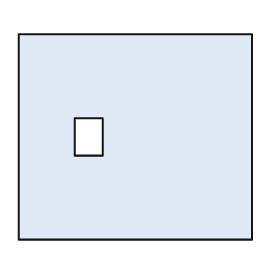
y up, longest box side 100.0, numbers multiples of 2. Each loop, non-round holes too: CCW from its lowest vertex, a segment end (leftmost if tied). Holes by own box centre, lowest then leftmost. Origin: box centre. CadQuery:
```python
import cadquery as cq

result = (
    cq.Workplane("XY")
    .moveTo(-50.0, -44.0)
    .lineTo(50.0, -44.0)
    .lineTo(50.0, 44.0)
    .lineTo(-50.0, 44.0)
    .close()
    .moveTo(-26.0, -8.0)
    .lineTo(-14.0, -8.0)
    .lineTo(-14.0, 8.0)
    .lineTo(-26.0, 8.0)
    .close()
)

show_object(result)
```